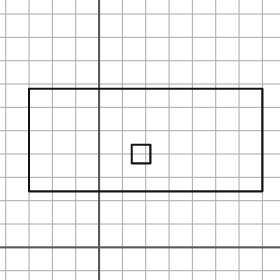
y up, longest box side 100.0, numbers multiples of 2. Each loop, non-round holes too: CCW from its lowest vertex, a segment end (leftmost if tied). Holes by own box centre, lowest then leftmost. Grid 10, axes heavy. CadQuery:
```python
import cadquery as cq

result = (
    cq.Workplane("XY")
    .moveTo(-30.0, 24.0)
    .lineTo(70.0, 24.0)
    .lineTo(70.0, 68.0)
    .lineTo(-30.0, 68.0)
    .close()
    .moveTo(14.0, 36.0)
    .lineTo(22.0, 36.0)
    .lineTo(22.0, 44.0)
    .lineTo(14.0, 44.0)
    .close()
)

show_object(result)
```